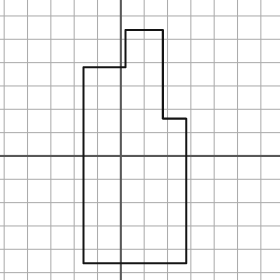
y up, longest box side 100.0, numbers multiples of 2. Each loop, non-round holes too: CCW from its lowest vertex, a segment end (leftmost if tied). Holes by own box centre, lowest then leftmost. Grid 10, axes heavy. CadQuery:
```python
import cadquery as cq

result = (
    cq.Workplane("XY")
    .moveTo(-16.0, -46.0)
    .lineTo(28.0, -46.0)
    .lineTo(28.0, 16.0)
    .lineTo(18.0, 16.0)
    .lineTo(18.0, 54.0)
    .lineTo(2.0, 54.0)
    .lineTo(2.0, 38.0)
    .lineTo(-16.0, 38.0)
    .close()
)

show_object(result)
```